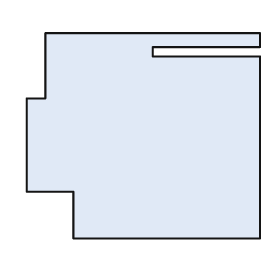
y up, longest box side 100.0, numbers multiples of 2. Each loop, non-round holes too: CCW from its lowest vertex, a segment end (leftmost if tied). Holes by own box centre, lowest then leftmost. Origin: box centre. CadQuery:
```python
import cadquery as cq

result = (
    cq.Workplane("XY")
    .moveTo(-30.0, -44.0)
    .lineTo(50.0, -44.0)
    .lineTo(50.0, 34.0)
    .lineTo(4.0, 34.0)
    .lineTo(4.0, 38.0)
    .lineTo(50.0, 38.0)
    .lineTo(50.0, 44.0)
    .lineTo(-42.0, 44.0)
    .lineTo(-42.0, 16.0)
    .lineTo(-50.0, 16.0)
    .lineTo(-50.0, -24.0)
    .lineTo(-30.0, -24.0)
    .close()
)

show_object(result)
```